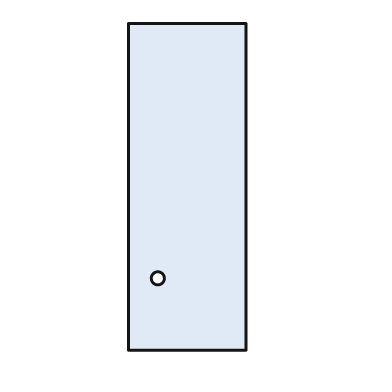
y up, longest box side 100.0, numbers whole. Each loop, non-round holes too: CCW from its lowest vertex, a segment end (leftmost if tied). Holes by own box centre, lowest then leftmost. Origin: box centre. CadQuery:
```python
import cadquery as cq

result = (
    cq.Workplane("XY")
    .moveTo(-18.0, -50.0)
    .lineTo(18.0, -50.0)
    .lineTo(18.0, 50.0)
    .lineTo(-18.0, 50.0)
    .close()
    .moveTo(-9.0, -28.0)
    .circle(2.0)
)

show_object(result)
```